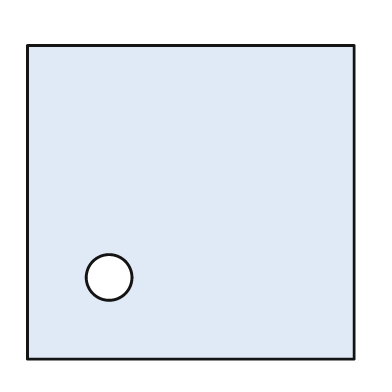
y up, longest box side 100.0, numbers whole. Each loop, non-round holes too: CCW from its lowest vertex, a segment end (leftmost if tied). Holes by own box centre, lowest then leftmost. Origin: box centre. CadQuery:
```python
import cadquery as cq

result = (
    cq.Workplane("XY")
    .moveTo(-50.0, -48.0)
    .lineTo(50.0, -48.0)
    .lineTo(50.0, 48.0)
    .lineTo(-50.0, 48.0)
    .close()
    .moveTo(-25.0, -23.0)
    .circle(7.0)
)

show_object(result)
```